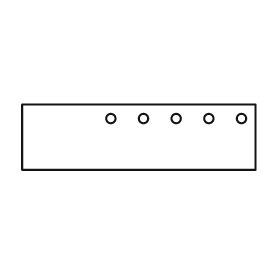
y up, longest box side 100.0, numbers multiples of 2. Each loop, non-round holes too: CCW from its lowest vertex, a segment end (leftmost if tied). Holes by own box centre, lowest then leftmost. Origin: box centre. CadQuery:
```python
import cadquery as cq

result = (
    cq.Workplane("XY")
    .moveTo(-50.0, -14.0)
    .lineTo(50.0, -14.0)
    .lineTo(50.0, 14.0)
    .lineTo(-50.0, 14.0)
    .close()
    .moveTo(-12.0, 8.0)
    .circle(2.0)
    .moveTo(2.0, 8.0)
    .circle(2.0)
    .moveTo(16.0, 8.0)
    .circle(2.0)
    .moveTo(30.0, 8.0)
    .circle(2.0)
    .moveTo(44.0, 8.0)
    .circle(2.0)
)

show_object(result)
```